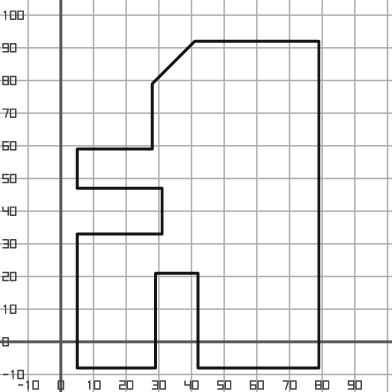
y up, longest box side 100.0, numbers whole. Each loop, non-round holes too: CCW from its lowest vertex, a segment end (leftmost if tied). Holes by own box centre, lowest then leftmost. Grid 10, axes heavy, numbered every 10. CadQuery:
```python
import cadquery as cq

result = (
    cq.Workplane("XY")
    .moveTo(5.0, -8.0)
    .lineTo(29.0, -8.0)
    .lineTo(29.0, 21.0)
    .lineTo(42.0, 21.0)
    .lineTo(42.0, -8.0)
    .lineTo(79.0, -8.0)
    .lineTo(79.0, 92.0)
    .lineTo(41.0, 92.0)
    .lineTo(28.0, 79.0)
    .lineTo(28.0, 59.0)
    .lineTo(5.0, 59.0)
    .lineTo(5.0, 47.0)
    .lineTo(31.0, 47.0)
    .lineTo(31.0, 33.0)
    .lineTo(5.0, 33.0)
    .close()
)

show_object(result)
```